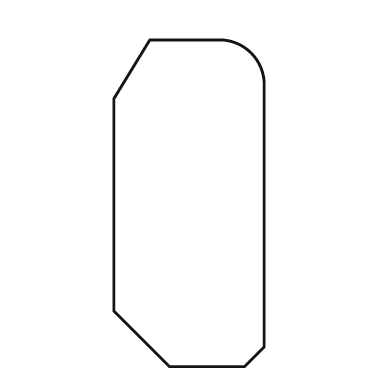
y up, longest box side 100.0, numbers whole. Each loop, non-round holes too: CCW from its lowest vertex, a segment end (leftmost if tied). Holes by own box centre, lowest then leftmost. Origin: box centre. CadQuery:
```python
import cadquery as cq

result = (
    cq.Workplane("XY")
    .moveTo(-6.0, -50.0)
    .lineTo(17.0, -50.0)
    .lineTo(23.0, -44.0)
    .lineTo(23.0, 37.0)
    .threePointArc((19.0, 46.0), (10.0, 50.0))
    .lineTo(-12.0, 50.0)
    .lineTo(-23.0, 32.0)
    .lineTo(-23.0, -33.0)
    .close()
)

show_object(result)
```